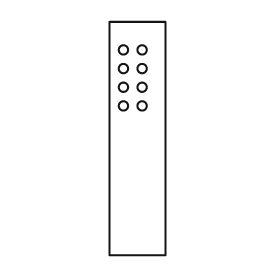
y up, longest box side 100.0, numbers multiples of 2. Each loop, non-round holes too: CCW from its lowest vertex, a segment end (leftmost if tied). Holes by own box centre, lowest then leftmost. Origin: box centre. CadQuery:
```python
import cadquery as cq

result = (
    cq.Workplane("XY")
    .moveTo(-12.0, -50.0)
    .lineTo(12.0, -50.0)
    .lineTo(12.0, 50.0)
    .lineTo(-12.0, 50.0)
    .close()
    .moveTo(-6.0, 14.0)
    .circle(2.0)
    .moveTo(2.0, 14.0)
    .circle(2.0)
    .moveTo(-6.0, 22.0)
    .circle(2.0)
    .moveTo(2.0, 22.0)
    .circle(2.0)
    .moveTo(-6.0, 30.0)
    .circle(2.0)
    .moveTo(2.0, 30.0)
    .circle(2.0)
    .moveTo(-6.0, 38.0)
    .circle(2.0)
    .moveTo(2.0, 38.0)
    .circle(2.0)
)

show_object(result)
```